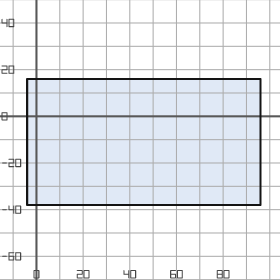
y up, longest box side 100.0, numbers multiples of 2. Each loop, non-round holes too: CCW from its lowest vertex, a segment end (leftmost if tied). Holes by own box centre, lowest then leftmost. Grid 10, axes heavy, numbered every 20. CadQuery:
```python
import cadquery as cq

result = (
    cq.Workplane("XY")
    .moveTo(-4.0, -38.0)
    .lineTo(96.0, -38.0)
    .lineTo(96.0, 16.0)
    .lineTo(-4.0, 16.0)
    .close()
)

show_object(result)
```